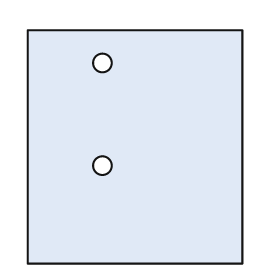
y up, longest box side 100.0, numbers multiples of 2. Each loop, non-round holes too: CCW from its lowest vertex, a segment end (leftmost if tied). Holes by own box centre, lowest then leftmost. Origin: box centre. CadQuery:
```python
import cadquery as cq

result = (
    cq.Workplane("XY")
    .moveTo(-46.0, -50.0)
    .lineTo(46.0, -50.0)
    .lineTo(46.0, 50.0)
    .lineTo(-46.0, 50.0)
    .close()
    .moveTo(-14.0, -8.0)
    .circle(4.0)
    .moveTo(-14.0, 36.0)
    .circle(4.0)
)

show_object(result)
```